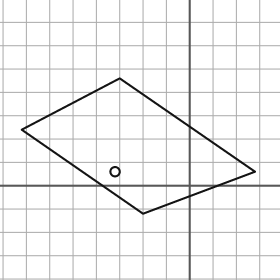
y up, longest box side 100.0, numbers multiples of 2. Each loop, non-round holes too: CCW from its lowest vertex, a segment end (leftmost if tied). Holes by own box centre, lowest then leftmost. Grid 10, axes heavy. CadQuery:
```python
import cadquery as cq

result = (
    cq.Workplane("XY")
    .moveTo(-20.0, -12.0)
    .lineTo(28.0, 6.0)
    .lineTo(-30.0, 46.0)
    .lineTo(-72.0, 24.0)
    .close()
    .moveTo(-32.0, 6.0)
    .circle(2.0)
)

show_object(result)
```